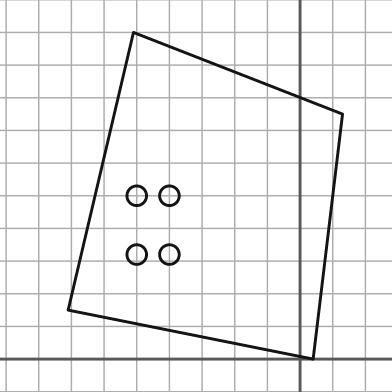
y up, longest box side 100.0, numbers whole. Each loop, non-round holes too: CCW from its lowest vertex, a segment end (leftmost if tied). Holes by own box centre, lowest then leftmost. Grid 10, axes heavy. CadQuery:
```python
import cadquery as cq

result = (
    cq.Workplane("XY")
    .moveTo(4.0, 0.0)
    .lineTo(13.0, 75.0)
    .lineTo(-51.0, 100.0)
    .lineTo(-71.0, 15.0)
    .close()
    .moveTo(-50.0, 32.0)
    .circle(3.0)
    .moveTo(-40.0, 32.0)
    .circle(3.0)
    .moveTo(-50.0, 50.0)
    .circle(3.0)
    .moveTo(-40.0, 50.0)
    .circle(3.0)
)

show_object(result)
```